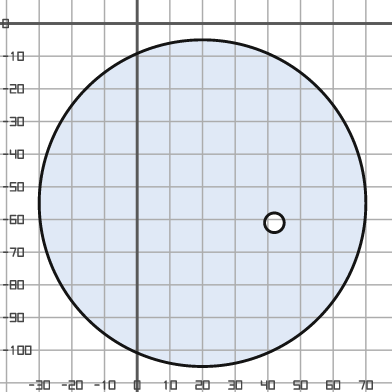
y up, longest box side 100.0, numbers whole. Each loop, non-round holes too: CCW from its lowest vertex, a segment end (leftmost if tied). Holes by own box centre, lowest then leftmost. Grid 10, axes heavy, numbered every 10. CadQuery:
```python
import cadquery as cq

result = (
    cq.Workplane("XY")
    .moveTo(20.0, -55.0)
    .circle(50.0)
    .moveTo(42.0, -61.0)
    .circle(3.0)
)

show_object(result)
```